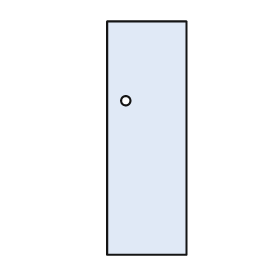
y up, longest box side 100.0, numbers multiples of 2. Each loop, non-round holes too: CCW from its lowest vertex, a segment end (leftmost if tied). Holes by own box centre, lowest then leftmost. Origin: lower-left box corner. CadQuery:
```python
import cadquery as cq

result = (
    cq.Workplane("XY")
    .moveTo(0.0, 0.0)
    .lineTo(34.0, 0.0)
    .lineTo(34.0, 100.0)
    .lineTo(0.0, 100.0)
    .close()
    .moveTo(8.0, 66.0)
    .circle(2.0)
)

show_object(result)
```